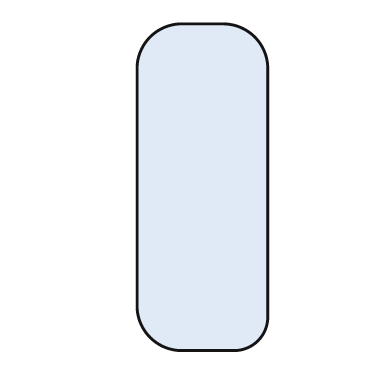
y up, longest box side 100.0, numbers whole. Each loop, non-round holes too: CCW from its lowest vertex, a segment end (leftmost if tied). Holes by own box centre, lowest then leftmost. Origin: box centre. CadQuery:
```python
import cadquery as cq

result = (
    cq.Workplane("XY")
    .moveTo(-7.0, -50.0)
    .lineTo(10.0, -50.0)
    .threePointArc((17.0, -47.0), (20.0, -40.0))
    .lineTo(20.0, 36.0)
    .threePointArc((16.0, 46.0), (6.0, 50.0))
    .lineTo(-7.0, 50.0)
    .threePointArc((-16.0, 46.0), (-20.0, 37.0))
    .lineTo(-20.0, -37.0)
    .threePointArc((-16.0, -46.0), (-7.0, -50.0))
    .close()
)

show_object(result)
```